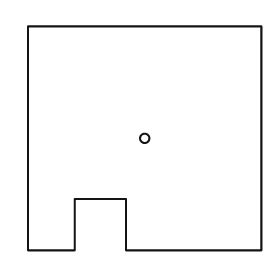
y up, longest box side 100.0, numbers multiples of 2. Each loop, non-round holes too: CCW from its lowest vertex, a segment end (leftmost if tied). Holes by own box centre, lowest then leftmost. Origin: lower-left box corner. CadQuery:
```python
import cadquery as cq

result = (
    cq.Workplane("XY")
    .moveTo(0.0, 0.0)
    .lineTo(20.0, 0.0)
    .lineTo(20.0, 22.0)
    .lineTo(42.0, 22.0)
    .lineTo(42.0, 0.0)
    .lineTo(100.0, 0.0)
    .lineTo(100.0, 96.0)
    .lineTo(0.0, 96.0)
    .close()
    .moveTo(50.0, 48.0)
    .circle(2.0)
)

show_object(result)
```